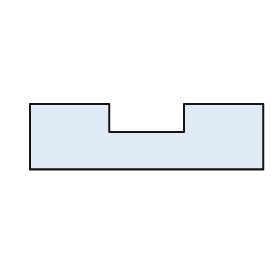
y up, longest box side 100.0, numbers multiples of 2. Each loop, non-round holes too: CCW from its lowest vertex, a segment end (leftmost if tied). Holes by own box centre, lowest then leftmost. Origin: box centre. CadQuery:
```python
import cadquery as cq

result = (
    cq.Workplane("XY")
    .moveTo(-50.0, -14.0)
    .lineTo(50.0, -14.0)
    .lineTo(50.0, 14.0)
    .lineTo(16.0, 14.0)
    .lineTo(16.0, 2.0)
    .lineTo(-16.0, 2.0)
    .lineTo(-16.0, 14.0)
    .lineTo(-50.0, 14.0)
    .close()
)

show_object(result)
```